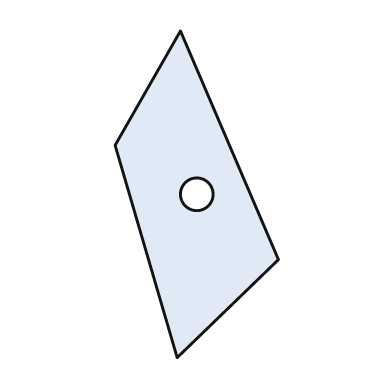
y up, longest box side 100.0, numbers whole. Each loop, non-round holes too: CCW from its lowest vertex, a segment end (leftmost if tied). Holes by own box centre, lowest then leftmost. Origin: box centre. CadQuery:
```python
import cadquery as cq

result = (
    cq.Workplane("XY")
    .moveTo(-6.0, -50.0)
    .lineTo(25.0, -20.0)
    .lineTo(-5.0, 50.0)
    .lineTo(-25.0, 15.0)
    .close()
    .moveTo(0.0, 0.0)
    .circle(5.0)
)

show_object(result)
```